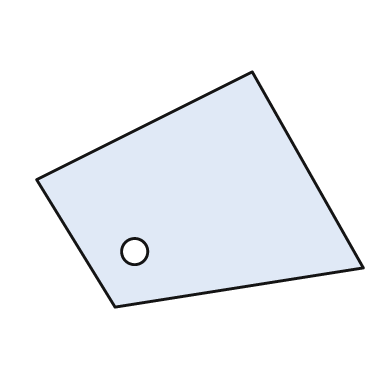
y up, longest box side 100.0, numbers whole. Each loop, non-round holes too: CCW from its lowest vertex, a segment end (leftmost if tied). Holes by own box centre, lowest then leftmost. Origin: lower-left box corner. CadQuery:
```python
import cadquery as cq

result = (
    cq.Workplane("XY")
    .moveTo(24.0, 0.0)
    .lineTo(100.0, 12.0)
    .lineTo(66.0, 72.0)
    .lineTo(0.0, 39.0)
    .close()
    .moveTo(30.0, 17.0)
    .circle(4.0)
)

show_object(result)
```